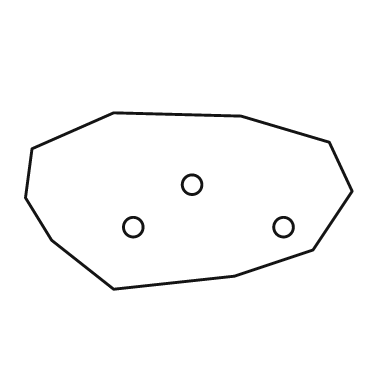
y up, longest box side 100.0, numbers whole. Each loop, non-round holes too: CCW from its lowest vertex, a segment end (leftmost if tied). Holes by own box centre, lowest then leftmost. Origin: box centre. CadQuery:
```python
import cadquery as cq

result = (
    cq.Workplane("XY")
    .moveTo(-23.0, -27.0)
    .lineTo(14.0, -23.0)
    .lineTo(38.0, -15.0)
    .lineTo(50.0, 3.0)
    .lineTo(43.0, 18.0)
    .lineTo(16.0, 26.0)
    .lineTo(-23.0, 27.0)
    .lineTo(-48.0, 16.0)
    .lineTo(-50.0, 1.0)
    .lineTo(-42.0, -12.0)
    .close()
    .moveTo(-17.0, -8.0)
    .circle(3.0)
    .moveTo(29.0, -8.0)
    .circle(3.0)
    .moveTo(1.0, 5.0)
    .circle(3.0)
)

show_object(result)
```